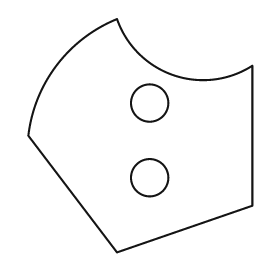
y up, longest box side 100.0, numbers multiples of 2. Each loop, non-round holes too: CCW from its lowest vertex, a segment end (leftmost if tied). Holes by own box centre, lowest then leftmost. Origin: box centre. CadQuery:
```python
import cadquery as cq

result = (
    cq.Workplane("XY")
    .moveTo(-10.0, -50.0)
    .lineTo(48.0, -30.0)
    .lineTo(48.0, 30.0)
    .threePointArc((14.0, 26.0), (-10.0, 50.0))
    .threePointArc((-36.0, 30.0), (-48.0, 0.0))
    .close()
    .moveTo(4.0, -18.0)
    .circle(8.0)
    .moveTo(4.0, 14.0)
    .circle(8.0)
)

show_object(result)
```